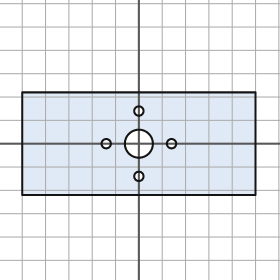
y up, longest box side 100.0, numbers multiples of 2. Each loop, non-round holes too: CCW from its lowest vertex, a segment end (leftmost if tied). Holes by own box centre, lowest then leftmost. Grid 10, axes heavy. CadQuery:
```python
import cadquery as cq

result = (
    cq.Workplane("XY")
    .moveTo(-50.0, -22.0)
    .lineTo(50.0, -22.0)
    .lineTo(50.0, 22.0)
    .lineTo(-50.0, 22.0)
    .close()
    .moveTo(0.0, -14.0)
    .circle(2.0)
    .moveTo(-14.0, 0.0)
    .circle(2.0)
    .moveTo(0.0, 0.0)
    .circle(6.0)
    .moveTo(14.0, 0.0)
    .circle(2.0)
    .moveTo(0.0, 14.0)
    .circle(2.0)
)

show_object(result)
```